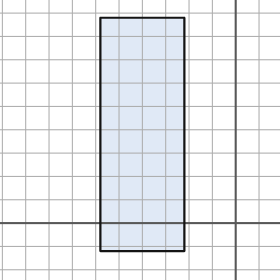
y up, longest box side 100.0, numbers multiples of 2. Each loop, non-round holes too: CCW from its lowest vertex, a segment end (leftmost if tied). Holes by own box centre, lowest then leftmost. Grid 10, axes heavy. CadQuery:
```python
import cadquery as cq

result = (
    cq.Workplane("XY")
    .moveTo(-58.0, -12.0)
    .lineTo(-22.0, -12.0)
    .lineTo(-22.0, 88.0)
    .lineTo(-58.0, 88.0)
    .close()
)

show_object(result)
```